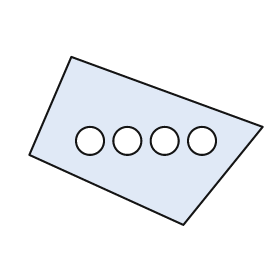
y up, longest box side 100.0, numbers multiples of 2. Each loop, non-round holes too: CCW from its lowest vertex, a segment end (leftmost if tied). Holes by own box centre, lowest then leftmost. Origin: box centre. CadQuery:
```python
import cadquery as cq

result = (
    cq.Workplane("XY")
    .moveTo(16.0, -36.0)
    .lineTo(50.0, 6.0)
    .lineTo(-32.0, 36.0)
    .lineTo(-50.0, -6.0)
    .close()
    .moveTo(-24.0, 0.0)
    .circle(6.0)
    .moveTo(-8.0, 0.0)
    .circle(6.0)
    .moveTo(8.0, 0.0)
    .circle(6.0)
    .moveTo(24.0, 0.0)
    .circle(6.0)
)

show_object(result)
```